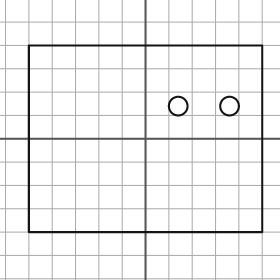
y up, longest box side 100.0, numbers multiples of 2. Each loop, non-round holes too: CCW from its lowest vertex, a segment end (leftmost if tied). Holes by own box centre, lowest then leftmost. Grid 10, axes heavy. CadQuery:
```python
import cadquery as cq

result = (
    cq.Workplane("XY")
    .moveTo(-50.0, -40.0)
    .lineTo(50.0, -40.0)
    .lineTo(50.0, 40.0)
    .lineTo(-50.0, 40.0)
    .close()
    .moveTo(14.0, 14.0)
    .circle(4.0)
    .moveTo(36.0, 14.0)
    .circle(4.0)
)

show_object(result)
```